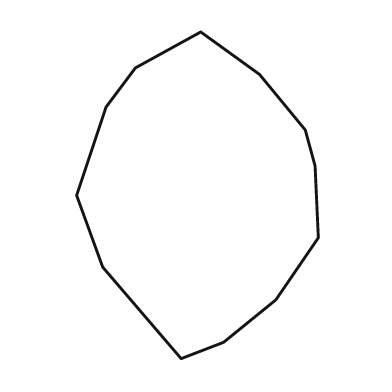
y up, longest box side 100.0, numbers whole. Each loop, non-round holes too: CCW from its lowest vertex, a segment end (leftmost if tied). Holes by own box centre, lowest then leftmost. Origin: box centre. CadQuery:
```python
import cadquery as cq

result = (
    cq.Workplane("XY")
    .moveTo(-5.0, -50.0)
    .lineTo(8.0, -45.0)
    .lineTo(24.0, -32.0)
    .lineTo(37.0, -13.0)
    .lineTo(36.0, 9.0)
    .lineTo(33.0, 20.0)
    .lineTo(19.0, 37.0)
    .lineTo(1.0, 50.0)
    .lineTo(-19.0, 39.0)
    .lineTo(-28.0, 27.0)
    .lineTo(-37.0, 0.0)
    .lineTo(-29.0, -22.0)
    .close()
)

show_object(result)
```